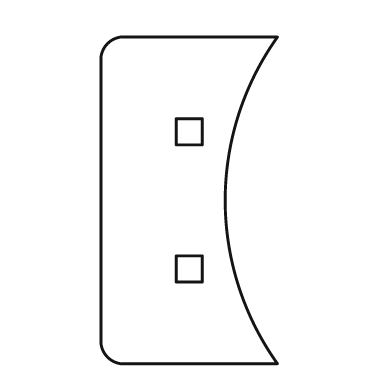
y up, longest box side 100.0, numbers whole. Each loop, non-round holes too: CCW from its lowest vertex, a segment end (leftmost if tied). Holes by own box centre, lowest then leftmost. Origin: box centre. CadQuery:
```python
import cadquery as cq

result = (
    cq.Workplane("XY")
    .moveTo(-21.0, -50.0)
    .lineTo(27.0, -50.0)
    .threePointArc((11.0, 0.0), (27.0, 50.0))
    .lineTo(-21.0, 50.0)
    .threePointArc((-25.0, 48.0), (-27.0, 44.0))
    .lineTo(-27.0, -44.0)
    .threePointArc((-25.0, -48.0), (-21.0, -50.0))
    .close()
    .moveTo(-4.0, -25.0)
    .lineTo(4.0, -25.0)
    .lineTo(4.0, -17.0)
    .lineTo(-4.0, -17.0)
    .close()
    .moveTo(-4.0, 17.0)
    .lineTo(4.0, 17.0)
    .lineTo(4.0, 25.0)
    .lineTo(-4.0, 25.0)
    .close()
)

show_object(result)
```